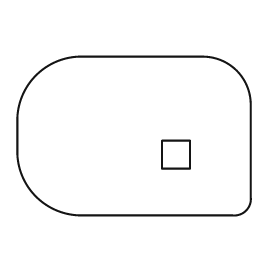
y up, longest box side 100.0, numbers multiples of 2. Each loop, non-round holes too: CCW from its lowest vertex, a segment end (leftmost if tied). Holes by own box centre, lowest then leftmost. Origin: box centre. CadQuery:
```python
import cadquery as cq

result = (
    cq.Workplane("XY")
    .moveTo(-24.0, -34.0)
    .lineTo(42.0, -34.0)
    .threePointArc((48.0, -32.0), (50.0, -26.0))
    .lineTo(50.0, 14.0)
    .threePointArc((44.0, 28.0), (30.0, 34.0))
    .lineTo(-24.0, 34.0)
    .threePointArc((-42.0, 26.0), (-50.0, 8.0))
    .lineTo(-50.0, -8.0)
    .threePointArc((-42.0, -26.0), (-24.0, -34.0))
    .close()
    .moveTo(12.0, -14.0)
    .lineTo(24.0, -14.0)
    .lineTo(24.0, -2.0)
    .lineTo(12.0, -2.0)
    .close()
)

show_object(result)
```